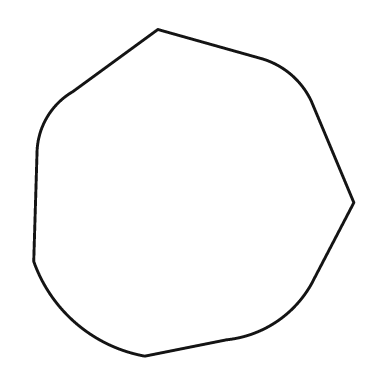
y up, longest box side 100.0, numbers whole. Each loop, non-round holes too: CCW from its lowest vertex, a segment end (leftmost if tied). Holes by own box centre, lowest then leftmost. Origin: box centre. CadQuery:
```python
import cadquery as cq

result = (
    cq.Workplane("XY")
    .moveTo(-15.0, -50.0)
    .lineTo(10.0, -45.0)
    .threePointArc((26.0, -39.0), (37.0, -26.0))
    .lineTo(49.0, -3.0)
    .lineTo(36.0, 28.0)
    .threePointArc((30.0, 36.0), (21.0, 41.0))
    .lineTo(-11.0, 50.0)
    .lineTo(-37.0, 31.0)
    .threePointArc((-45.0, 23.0), (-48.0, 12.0))
    .lineTo(-49.0, -21.0)
    .threePointArc((-36.0, -40.0), (-15.0, -50.0))
    .close()
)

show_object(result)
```